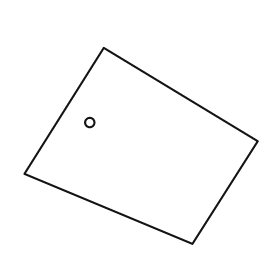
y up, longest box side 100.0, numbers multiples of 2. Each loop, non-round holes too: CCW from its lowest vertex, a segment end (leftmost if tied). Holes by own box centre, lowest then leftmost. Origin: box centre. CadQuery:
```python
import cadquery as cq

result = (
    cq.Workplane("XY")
    .moveTo(22.0, -42.0)
    .lineTo(50.0, 2.0)
    .lineTo(-16.0, 42.0)
    .lineTo(-50.0, -12.0)
    .close()
    .moveTo(-22.0, 10.0)
    .circle(2.0)
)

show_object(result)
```